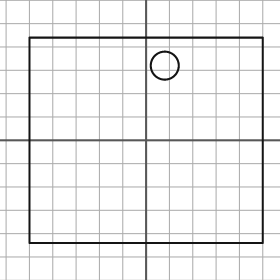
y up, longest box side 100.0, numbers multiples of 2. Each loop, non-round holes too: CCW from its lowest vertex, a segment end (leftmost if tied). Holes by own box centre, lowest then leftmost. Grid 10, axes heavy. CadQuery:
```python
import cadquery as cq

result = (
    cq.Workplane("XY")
    .moveTo(-50.0, -44.0)
    .lineTo(50.0, -44.0)
    .lineTo(50.0, 44.0)
    .lineTo(-50.0, 44.0)
    .close()
    .moveTo(8.0, 32.0)
    .circle(6.0)
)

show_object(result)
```